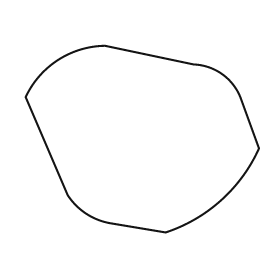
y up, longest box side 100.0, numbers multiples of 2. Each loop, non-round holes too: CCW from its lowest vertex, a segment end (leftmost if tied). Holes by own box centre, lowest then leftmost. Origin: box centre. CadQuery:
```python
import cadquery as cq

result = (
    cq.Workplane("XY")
    .moveTo(10.0, -40.0)
    .threePointArc((34.0, -26.0), (50.0, -4.0))
    .lineTo(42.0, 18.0)
    .threePointArc((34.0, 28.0), (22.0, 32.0))
    .lineTo(-16.0, 40.0)
    .threePointArc((-36.0, 34.0), (-50.0, 18.0))
    .lineTo(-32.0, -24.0)
    .threePointArc((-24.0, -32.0), (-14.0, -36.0))
    .close()
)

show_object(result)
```